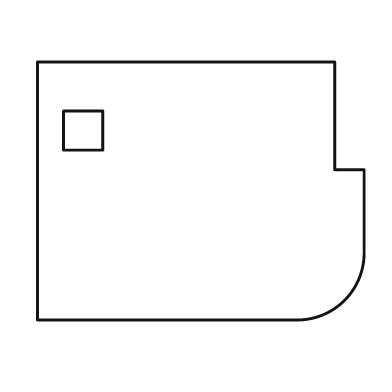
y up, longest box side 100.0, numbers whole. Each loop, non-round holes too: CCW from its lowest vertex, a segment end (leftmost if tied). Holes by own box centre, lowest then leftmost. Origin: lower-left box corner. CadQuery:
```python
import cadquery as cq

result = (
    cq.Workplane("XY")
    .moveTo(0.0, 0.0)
    .lineTo(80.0, 0.0)
    .threePointArc((94.0, 6.0), (100.0, 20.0))
    .lineTo(100.0, 46.0)
    .lineTo(91.0, 46.0)
    .lineTo(91.0, 79.0)
    .lineTo(0.0, 79.0)
    .close()
    .moveTo(8.0, 52.0)
    .lineTo(20.0, 52.0)
    .lineTo(20.0, 64.0)
    .lineTo(8.0, 64.0)
    .close()
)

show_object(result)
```